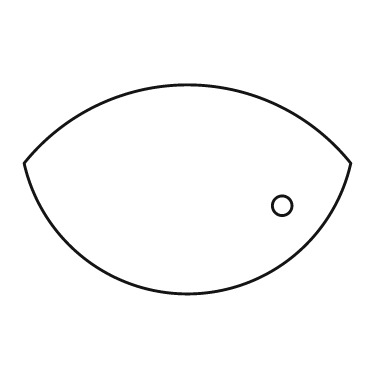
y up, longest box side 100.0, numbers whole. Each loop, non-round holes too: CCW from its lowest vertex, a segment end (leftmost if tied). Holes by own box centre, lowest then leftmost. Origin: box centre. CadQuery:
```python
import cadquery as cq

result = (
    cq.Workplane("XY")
    .moveTo(-50.0, 8.0)
    .threePointArc((0.0, -32.0), (50.0, 8.0))
    .threePointArc((0.0, 32.0), (-50.0, 8.0))
    .close()
    .moveTo(29.0, -5.0)
    .circle(3.0)
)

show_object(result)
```